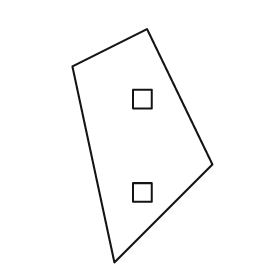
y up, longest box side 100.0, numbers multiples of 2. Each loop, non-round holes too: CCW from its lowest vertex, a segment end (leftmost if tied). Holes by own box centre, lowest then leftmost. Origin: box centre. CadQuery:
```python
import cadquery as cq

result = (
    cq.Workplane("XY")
    .moveTo(-12.0, -50.0)
    .lineTo(30.0, -8.0)
    .lineTo(2.0, 50.0)
    .lineTo(-30.0, 34.0)
    .close()
    .moveTo(-4.0, -24.0)
    .lineTo(4.0, -24.0)
    .lineTo(4.0, -16.0)
    .lineTo(-4.0, -16.0)
    .close()
    .moveTo(-4.0, 16.0)
    .lineTo(4.0, 16.0)
    .lineTo(4.0, 24.0)
    .lineTo(-4.0, 24.0)
    .close()
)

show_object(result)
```